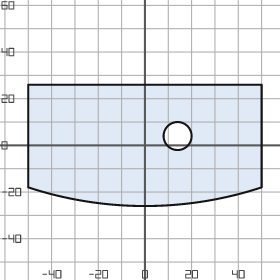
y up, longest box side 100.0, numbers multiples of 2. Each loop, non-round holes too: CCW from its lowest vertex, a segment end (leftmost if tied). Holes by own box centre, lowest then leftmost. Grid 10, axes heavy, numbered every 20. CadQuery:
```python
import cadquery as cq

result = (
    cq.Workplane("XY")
    .moveTo(-50.0, -18.0)
    .threePointArc((0.0, -26.0), (50.0, -18.0))
    .lineTo(50.0, 26.0)
    .lineTo(-50.0, 26.0)
    .close()
    .moveTo(14.0, 4.0)
    .circle(6.0)
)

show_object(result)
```